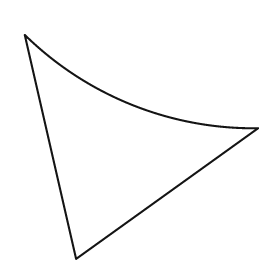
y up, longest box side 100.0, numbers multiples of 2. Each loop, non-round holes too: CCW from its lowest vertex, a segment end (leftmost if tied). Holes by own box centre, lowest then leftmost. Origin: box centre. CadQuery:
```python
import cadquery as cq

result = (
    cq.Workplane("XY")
    .moveTo(-28.0, -48.0)
    .lineTo(50.0, 8.0)
    .threePointArc((-4.0, 18.0), (-50.0, 48.0))
    .close()
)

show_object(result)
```